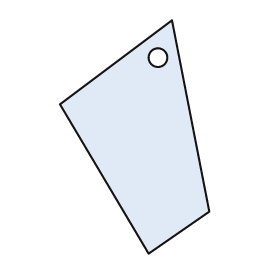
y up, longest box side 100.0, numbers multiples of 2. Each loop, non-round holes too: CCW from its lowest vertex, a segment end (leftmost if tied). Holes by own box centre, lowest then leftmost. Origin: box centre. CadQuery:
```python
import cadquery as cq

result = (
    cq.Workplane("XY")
    .moveTo(6.0, -50.0)
    .lineTo(32.0, -32.0)
    .lineTo(16.0, 50.0)
    .lineTo(-32.0, 14.0)
    .close()
    .moveTo(10.0, 34.0)
    .circle(4.0)
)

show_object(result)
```